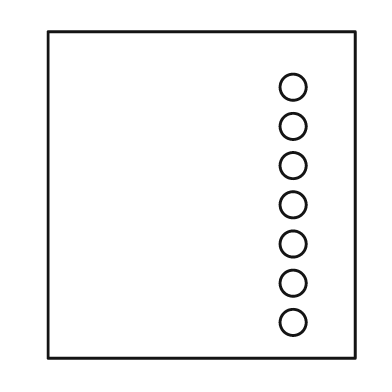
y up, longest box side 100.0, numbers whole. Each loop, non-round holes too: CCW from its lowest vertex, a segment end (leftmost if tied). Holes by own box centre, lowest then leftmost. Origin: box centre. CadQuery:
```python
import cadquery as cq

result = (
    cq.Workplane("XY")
    .moveTo(-47.0, -50.0)
    .lineTo(47.0, -50.0)
    .lineTo(47.0, 50.0)
    .lineTo(-47.0, 50.0)
    .close()
    .moveTo(28.0, -39.0)
    .circle(4.0)
    .moveTo(28.0, -27.0)
    .circle(4.0)
    .moveTo(28.0, -15.0)
    .circle(4.0)
    .moveTo(28.0, -3.0)
    .circle(4.0)
    .moveTo(28.0, 9.0)
    .circle(4.0)
    .moveTo(28.0, 21.0)
    .circle(4.0)
    .moveTo(28.0, 33.0)
    .circle(4.0)
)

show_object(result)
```